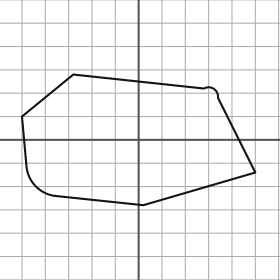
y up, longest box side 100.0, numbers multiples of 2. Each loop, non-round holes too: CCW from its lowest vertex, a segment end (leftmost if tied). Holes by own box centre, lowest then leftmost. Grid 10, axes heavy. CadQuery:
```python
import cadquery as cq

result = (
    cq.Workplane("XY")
    .moveTo(2.0, -28.0)
    .lineTo(50.0, -14.0)
    .lineTo(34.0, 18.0)
    .threePointArc((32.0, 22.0), (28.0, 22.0))
    .lineTo(-28.0, 28.0)
    .lineTo(-50.0, 10.0)
    .lineTo(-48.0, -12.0)
    .threePointArc((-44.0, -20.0), (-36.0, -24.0))
    .close()
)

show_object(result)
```